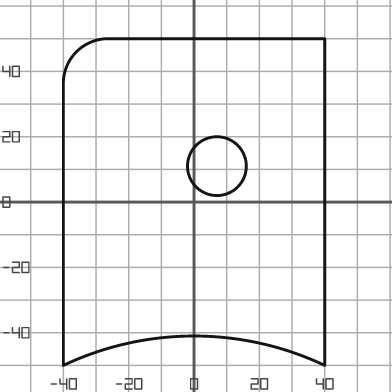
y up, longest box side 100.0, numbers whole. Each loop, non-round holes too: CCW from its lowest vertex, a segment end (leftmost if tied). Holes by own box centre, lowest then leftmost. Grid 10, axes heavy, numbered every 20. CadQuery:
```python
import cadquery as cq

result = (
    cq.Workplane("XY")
    .moveTo(-40.0, -50.0)
    .threePointArc((0.0, -41.0), (40.0, -50.0))
    .lineTo(40.0, 50.0)
    .lineTo(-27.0, 50.0)
    .threePointArc((-36.0, 46.0), (-40.0, 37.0))
    .close()
    .moveTo(7.0, 11.0)
    .circle(9.0)
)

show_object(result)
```